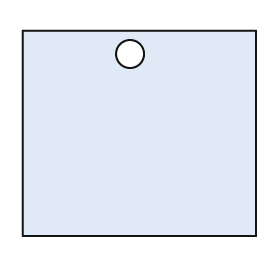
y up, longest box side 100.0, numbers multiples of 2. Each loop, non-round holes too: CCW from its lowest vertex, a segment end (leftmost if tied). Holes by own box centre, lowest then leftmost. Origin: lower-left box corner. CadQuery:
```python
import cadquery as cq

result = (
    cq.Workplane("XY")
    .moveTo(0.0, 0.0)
    .lineTo(100.0, 0.0)
    .lineTo(100.0, 88.0)
    .lineTo(0.0, 88.0)
    .close()
    .moveTo(46.0, 78.0)
    .circle(6.0)
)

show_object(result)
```